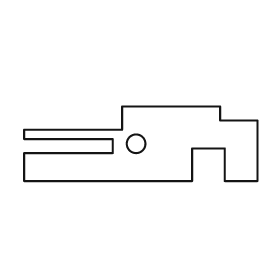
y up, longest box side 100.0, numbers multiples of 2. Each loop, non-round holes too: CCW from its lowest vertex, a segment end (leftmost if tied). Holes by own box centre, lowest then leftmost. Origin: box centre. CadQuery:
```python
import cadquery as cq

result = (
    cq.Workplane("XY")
    .moveTo(-50.0, -16.0)
    .lineTo(22.0, -16.0)
    .lineTo(22.0, -2.0)
    .lineTo(36.0, -2.0)
    .lineTo(36.0, -16.0)
    .lineTo(50.0, -16.0)
    .lineTo(50.0, 10.0)
    .lineTo(34.0, 10.0)
    .lineTo(34.0, 16.0)
    .lineTo(-8.0, 16.0)
    .lineTo(-8.0, 6.0)
    .lineTo(-50.0, 6.0)
    .lineTo(-50.0, 2.0)
    .lineTo(-12.0, 2.0)
    .lineTo(-12.0, -4.0)
    .lineTo(-50.0, -4.0)
    .close()
    .moveTo(-2.0, 0.0)
    .circle(4.0)
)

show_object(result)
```